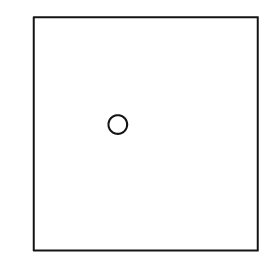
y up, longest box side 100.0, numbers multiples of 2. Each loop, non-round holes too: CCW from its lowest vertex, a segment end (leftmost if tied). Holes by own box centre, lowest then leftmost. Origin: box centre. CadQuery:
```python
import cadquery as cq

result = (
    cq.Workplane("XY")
    .moveTo(-48.0, -50.0)
    .lineTo(48.0, -50.0)
    .lineTo(48.0, 50.0)
    .lineTo(-48.0, 50.0)
    .close()
    .moveTo(-12.0, 4.0)
    .circle(4.0)
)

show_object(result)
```